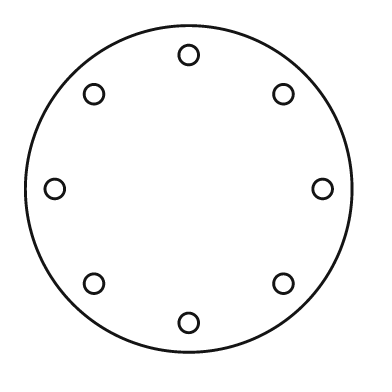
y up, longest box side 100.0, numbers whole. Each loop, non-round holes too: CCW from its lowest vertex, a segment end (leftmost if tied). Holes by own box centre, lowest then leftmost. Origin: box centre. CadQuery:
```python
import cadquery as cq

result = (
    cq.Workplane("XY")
    .moveTo(0.0, 0.0)
    .circle(50.0)
    .moveTo(0.0, -41.0)
    .circle(3.0)
    .moveTo(-29.0, -29.0)
    .circle(3.0)
    .moveTo(29.0, -29.0)
    .circle(3.0)
    .moveTo(-41.0, 0.0)
    .circle(3.0)
    .moveTo(41.0, 0.0)
    .circle(3.0)
    .moveTo(-29.0, 29.0)
    .circle(3.0)
    .moveTo(29.0, 29.0)
    .circle(3.0)
    .moveTo(0.0, 41.0)
    .circle(3.0)
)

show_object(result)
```